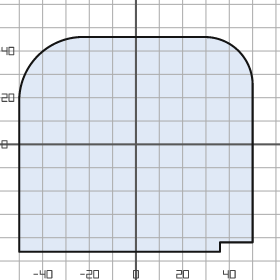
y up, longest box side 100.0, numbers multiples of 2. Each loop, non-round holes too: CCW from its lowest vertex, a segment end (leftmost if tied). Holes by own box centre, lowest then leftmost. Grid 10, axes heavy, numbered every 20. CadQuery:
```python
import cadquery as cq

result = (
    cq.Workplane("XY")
    .moveTo(-50.0, -46.0)
    .lineTo(36.0, -46.0)
    .lineTo(36.0, -42.0)
    .lineTo(50.0, -42.0)
    .lineTo(50.0, 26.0)
    .threePointArc((44.0, 40.0), (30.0, 46.0))
    .lineTo(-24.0, 46.0)
    .threePointArc((-42.0, 38.0), (-50.0, 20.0))
    .close()
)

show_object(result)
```